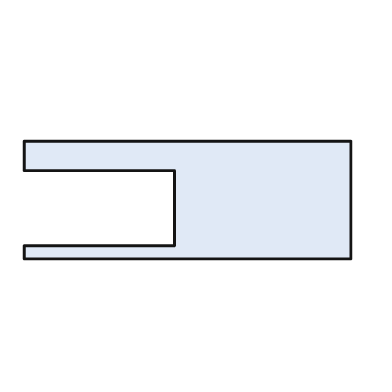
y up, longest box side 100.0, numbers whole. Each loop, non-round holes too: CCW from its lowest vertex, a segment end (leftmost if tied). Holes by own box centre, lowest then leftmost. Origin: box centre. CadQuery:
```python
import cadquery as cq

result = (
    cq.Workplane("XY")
    .moveTo(-50.0, -18.0)
    .lineTo(50.0, -18.0)
    .lineTo(50.0, 18.0)
    .lineTo(-50.0, 18.0)
    .lineTo(-50.0, 9.0)
    .lineTo(-4.0, 9.0)
    .lineTo(-4.0, -14.0)
    .lineTo(-50.0, -14.0)
    .close()
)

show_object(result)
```